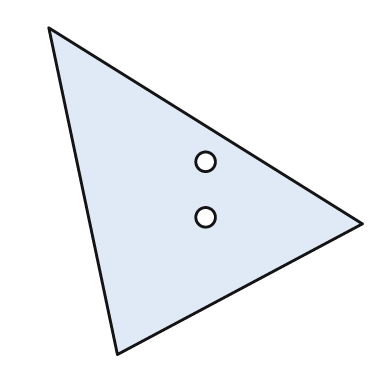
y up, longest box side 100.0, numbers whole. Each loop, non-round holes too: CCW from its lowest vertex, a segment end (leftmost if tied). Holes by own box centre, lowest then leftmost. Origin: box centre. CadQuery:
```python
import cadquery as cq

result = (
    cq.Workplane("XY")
    .moveTo(-27.0, -50.0)
    .lineTo(48.0, -10.0)
    .lineTo(-48.0, 50.0)
    .close()
    .moveTo(0.0, -8.0)
    .circle(3.0)
    .moveTo(0.0, 9.0)
    .circle(3.0)
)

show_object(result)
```